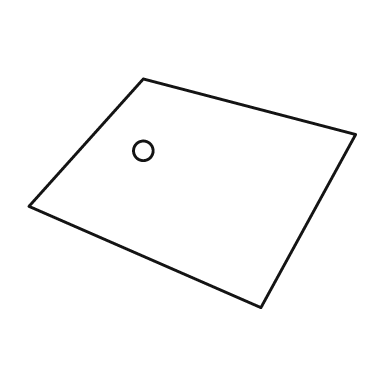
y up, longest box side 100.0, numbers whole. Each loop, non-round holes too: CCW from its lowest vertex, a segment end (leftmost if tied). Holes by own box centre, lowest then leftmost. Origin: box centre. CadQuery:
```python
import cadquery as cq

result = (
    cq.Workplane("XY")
    .moveTo(21.0, -35.0)
    .lineTo(50.0, 18.0)
    .lineTo(-15.0, 35.0)
    .lineTo(-50.0, -4.0)
    .close()
    .moveTo(-15.0, 13.0)
    .circle(3.0)
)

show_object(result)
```